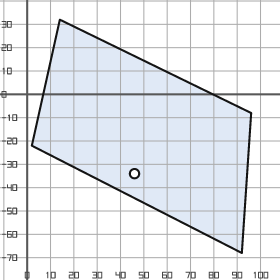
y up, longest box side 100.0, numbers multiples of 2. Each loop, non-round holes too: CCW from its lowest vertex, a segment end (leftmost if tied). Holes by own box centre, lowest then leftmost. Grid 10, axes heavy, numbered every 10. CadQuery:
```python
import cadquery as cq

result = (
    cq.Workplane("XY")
    .moveTo(92.0, -68.0)
    .lineTo(96.0, -8.0)
    .lineTo(14.0, 32.0)
    .lineTo(2.0, -22.0)
    .close()
    .moveTo(46.0, -34.0)
    .circle(2.0)
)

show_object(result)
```